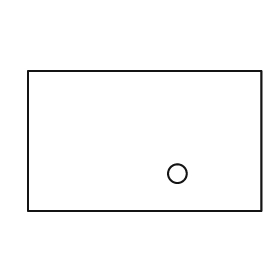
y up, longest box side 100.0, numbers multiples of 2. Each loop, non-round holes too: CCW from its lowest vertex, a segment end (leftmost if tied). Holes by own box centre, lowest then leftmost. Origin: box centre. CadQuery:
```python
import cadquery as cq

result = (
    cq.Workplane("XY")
    .moveTo(-50.0, -30.0)
    .lineTo(50.0, -30.0)
    .lineTo(50.0, 30.0)
    .lineTo(-50.0, 30.0)
    .close()
    .moveTo(14.0, -14.0)
    .circle(4.0)
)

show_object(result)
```